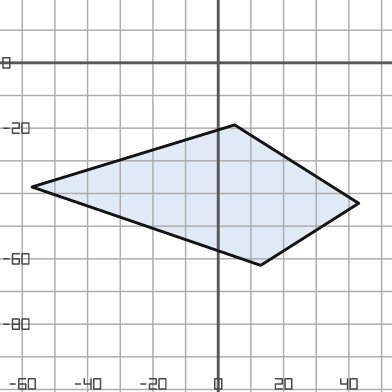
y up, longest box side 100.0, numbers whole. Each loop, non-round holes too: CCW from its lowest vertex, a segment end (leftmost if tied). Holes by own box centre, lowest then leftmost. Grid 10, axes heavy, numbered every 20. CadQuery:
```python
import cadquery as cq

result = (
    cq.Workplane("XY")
    .moveTo(13.0, -62.0)
    .lineTo(43.0, -43.0)
    .lineTo(5.0, -19.0)
    .lineTo(-57.0, -38.0)
    .close()
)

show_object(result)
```